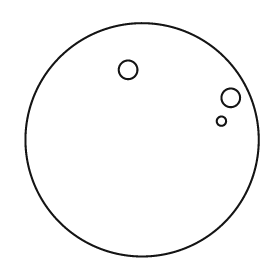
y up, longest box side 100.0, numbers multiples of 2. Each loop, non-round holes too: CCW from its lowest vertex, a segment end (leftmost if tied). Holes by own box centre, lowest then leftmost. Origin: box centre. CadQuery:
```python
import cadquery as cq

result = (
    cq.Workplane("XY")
    .moveTo(0.0, 0.0)
    .circle(50.0)
    .moveTo(34.0, 8.0)
    .circle(2.0)
    .moveTo(38.0, 18.0)
    .circle(4.0)
    .moveTo(-6.0, 30.0)
    .circle(4.0)
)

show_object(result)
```